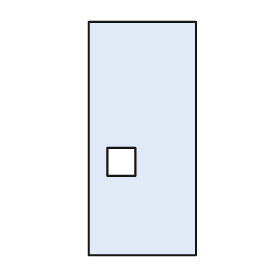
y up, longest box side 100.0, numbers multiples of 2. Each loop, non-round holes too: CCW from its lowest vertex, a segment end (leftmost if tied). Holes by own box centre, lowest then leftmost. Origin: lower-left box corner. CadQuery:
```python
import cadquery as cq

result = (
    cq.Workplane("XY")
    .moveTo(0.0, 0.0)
    .lineTo(46.0, 0.0)
    .lineTo(46.0, 100.0)
    .lineTo(0.0, 100.0)
    .close()
    .moveTo(8.0, 34.0)
    .lineTo(20.0, 34.0)
    .lineTo(20.0, 46.0)
    .lineTo(8.0, 46.0)
    .close()
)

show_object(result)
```